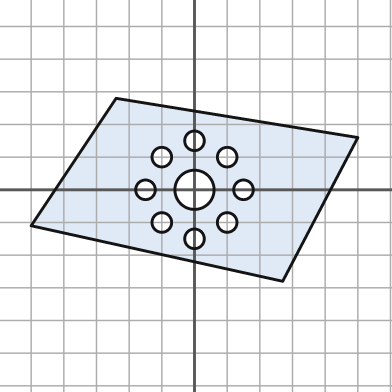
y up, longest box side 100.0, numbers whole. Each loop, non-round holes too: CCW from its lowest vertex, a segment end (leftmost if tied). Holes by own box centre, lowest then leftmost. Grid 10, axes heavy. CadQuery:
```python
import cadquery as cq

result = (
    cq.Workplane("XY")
    .moveTo(27.0, -28.0)
    .lineTo(50.0, 16.0)
    .lineTo(-24.0, 28.0)
    .lineTo(-50.0, -11.0)
    .close()
    .moveTo(0.0, -15.0)
    .circle(3.0)
    .moveTo(-10.0, -10.0)
    .circle(3.0)
    .moveTo(10.0, -10.0)
    .circle(3.0)
    .moveTo(-15.0, 0.0)
    .circle(3.0)
    .moveTo(0.0, 0.0)
    .circle(6.0)
    .moveTo(15.0, 0.0)
    .circle(3.0)
    .moveTo(-10.0, 10.0)
    .circle(3.0)
    .moveTo(10.0, 10.0)
    .circle(3.0)
    .moveTo(0.0, 15.0)
    .circle(3.0)
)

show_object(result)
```